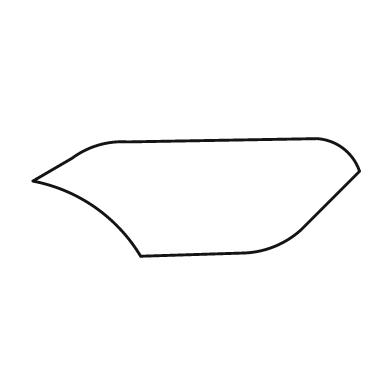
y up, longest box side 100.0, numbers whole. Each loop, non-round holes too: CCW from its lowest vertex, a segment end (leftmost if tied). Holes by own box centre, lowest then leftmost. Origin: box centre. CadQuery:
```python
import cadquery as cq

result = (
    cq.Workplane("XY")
    .moveTo(-17.0, -18.0)
    .lineTo(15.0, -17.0)
    .threePointArc((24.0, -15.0), (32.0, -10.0))
    .lineTo(50.0, 8.0)
    .threePointArc((45.0, 15.0), (37.0, 18.0))
    .lineTo(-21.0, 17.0)
    .threePointArc((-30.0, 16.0), (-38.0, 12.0))
    .lineTo(-50.0, 5.0)
    .threePointArc((-31.0, -3.0), (-17.0, -18.0))
    .close()
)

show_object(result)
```